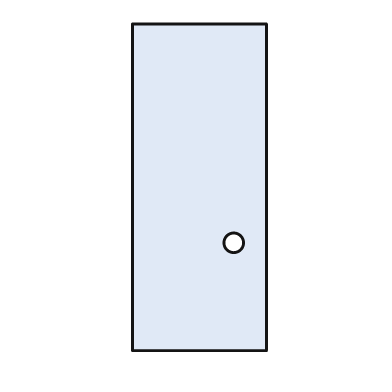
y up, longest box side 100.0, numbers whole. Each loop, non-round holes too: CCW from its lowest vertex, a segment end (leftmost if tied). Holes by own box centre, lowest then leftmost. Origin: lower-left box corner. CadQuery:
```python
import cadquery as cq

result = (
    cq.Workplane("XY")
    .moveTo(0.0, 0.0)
    .lineTo(41.0, 0.0)
    .lineTo(41.0, 100.0)
    .lineTo(0.0, 100.0)
    .close()
    .moveTo(31.0, 33.0)
    .circle(3.0)
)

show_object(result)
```